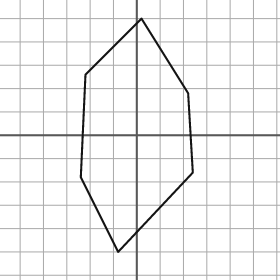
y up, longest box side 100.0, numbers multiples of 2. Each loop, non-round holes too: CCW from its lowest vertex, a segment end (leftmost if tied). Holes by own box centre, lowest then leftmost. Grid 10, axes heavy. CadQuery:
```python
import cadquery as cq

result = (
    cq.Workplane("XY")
    .moveTo(-8.0, -50.0)
    .lineTo(24.0, -16.0)
    .lineTo(22.0, 18.0)
    .lineTo(2.0, 50.0)
    .lineTo(-22.0, 26.0)
    .lineTo(-24.0, -18.0)
    .close()
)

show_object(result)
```